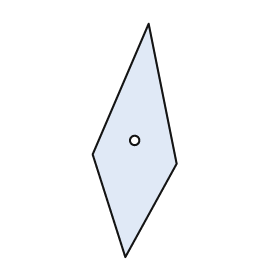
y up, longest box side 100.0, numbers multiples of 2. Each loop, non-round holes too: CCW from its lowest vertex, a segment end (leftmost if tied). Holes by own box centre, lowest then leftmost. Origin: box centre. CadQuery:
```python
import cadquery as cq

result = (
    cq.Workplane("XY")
    .moveTo(-4.0, -50.0)
    .lineTo(18.0, -10.0)
    .lineTo(6.0, 50.0)
    .lineTo(-18.0, -6.0)
    .close()
    .moveTo(0.0, 0.0)
    .circle(2.0)
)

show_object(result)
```